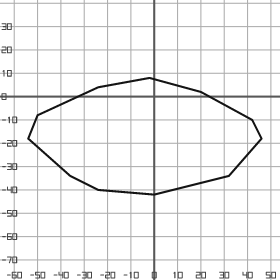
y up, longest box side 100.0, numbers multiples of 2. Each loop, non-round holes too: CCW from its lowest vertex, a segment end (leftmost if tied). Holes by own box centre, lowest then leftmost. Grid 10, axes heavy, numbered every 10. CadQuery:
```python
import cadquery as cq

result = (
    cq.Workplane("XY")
    .moveTo(0.0, -42.0)
    .lineTo(32.0, -34.0)
    .lineTo(46.0, -18.0)
    .lineTo(42.0, -10.0)
    .lineTo(20.0, 2.0)
    .lineTo(-2.0, 8.0)
    .lineTo(-24.0, 4.0)
    .lineTo(-50.0, -8.0)
    .lineTo(-54.0, -18.0)
    .lineTo(-36.0, -34.0)
    .lineTo(-24.0, -40.0)
    .close()
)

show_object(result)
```